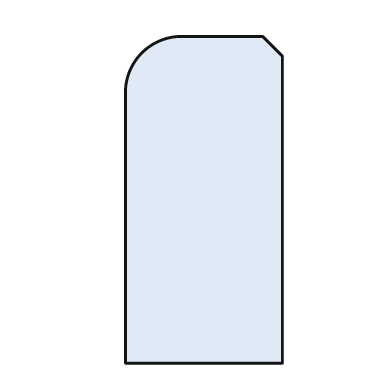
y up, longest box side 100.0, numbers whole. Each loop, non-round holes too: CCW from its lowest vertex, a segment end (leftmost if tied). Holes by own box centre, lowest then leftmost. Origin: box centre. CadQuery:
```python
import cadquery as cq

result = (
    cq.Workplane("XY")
    .moveTo(-24.0, -50.0)
    .lineTo(24.0, -50.0)
    .lineTo(24.0, 44.0)
    .lineTo(18.0, 50.0)
    .lineTo(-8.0, 50.0)
    .threePointArc((-19.0, 45.0), (-24.0, 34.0))
    .close()
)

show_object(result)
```